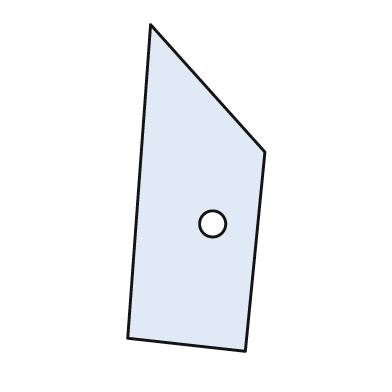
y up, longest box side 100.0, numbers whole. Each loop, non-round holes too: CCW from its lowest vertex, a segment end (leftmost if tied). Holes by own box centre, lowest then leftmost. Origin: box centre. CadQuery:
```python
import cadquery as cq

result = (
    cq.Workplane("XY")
    .moveTo(15.0, -50.0)
    .lineTo(21.0, 11.0)
    .lineTo(-14.0, 50.0)
    .lineTo(-21.0, -46.0)
    .close()
    .moveTo(5.0, -11.0)
    .circle(4.0)
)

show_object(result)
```